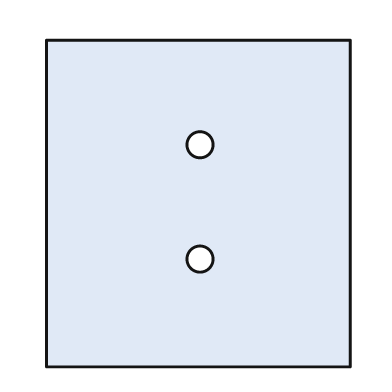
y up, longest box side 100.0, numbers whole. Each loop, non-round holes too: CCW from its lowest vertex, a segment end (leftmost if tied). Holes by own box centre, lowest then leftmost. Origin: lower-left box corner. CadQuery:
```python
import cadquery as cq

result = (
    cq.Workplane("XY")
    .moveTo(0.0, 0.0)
    .lineTo(93.0, 0.0)
    .lineTo(93.0, 100.0)
    .lineTo(0.0, 100.0)
    .close()
    .moveTo(47.0, 33.0)
    .circle(4.0)
    .moveTo(47.0, 68.0)
    .circle(4.0)
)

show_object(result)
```